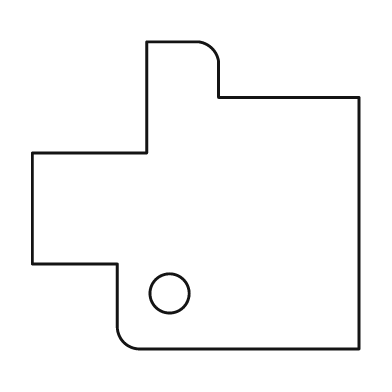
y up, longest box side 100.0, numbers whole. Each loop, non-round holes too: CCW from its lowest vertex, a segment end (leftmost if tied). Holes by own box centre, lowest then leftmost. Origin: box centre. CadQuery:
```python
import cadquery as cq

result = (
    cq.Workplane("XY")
    .moveTo(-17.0, -47.0)
    .lineTo(50.0, -47.0)
    .lineTo(50.0, 30.0)
    .lineTo(7.0, 30.0)
    .lineTo(7.0, 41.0)
    .threePointArc((5.0, 45.0), (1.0, 47.0))
    .lineTo(-15.0, 47.0)
    .lineTo(-15.0, 13.0)
    .lineTo(-50.0, 13.0)
    .lineTo(-50.0, -21.0)
    .lineTo(-24.0, -21.0)
    .lineTo(-24.0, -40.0)
    .threePointArc((-22.0, -45.0), (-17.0, -47.0))
    .close()
    .moveTo(-8.0, -30.0)
    .circle(6.0)
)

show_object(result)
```